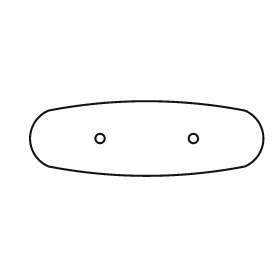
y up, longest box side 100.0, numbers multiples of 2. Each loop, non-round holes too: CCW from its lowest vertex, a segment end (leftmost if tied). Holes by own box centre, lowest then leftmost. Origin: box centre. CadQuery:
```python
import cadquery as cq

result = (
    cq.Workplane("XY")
    .moveTo(-42.0, -12.0)
    .threePointArc((0.0, -16.0), (42.0, -12.0))
    .threePointArc((50.0, 0.0), (42.0, 12.0))
    .threePointArc((0.0, 16.0), (-42.0, 12.0))
    .threePointArc((-50.0, 0.0), (-42.0, -12.0))
    .close()
    .moveTo(-20.0, 0.0)
    .circle(2.0)
    .moveTo(20.0, 0.0)
    .circle(2.0)
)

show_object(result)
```